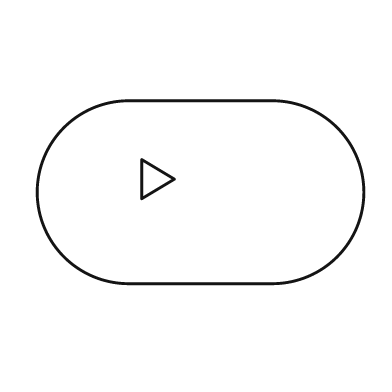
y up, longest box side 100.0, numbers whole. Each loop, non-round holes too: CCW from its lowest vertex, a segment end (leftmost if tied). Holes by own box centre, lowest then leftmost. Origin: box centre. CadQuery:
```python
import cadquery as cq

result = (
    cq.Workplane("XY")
    .moveTo(-22.0, -28.0)
    .lineTo(22.0, -28.0)
    .threePointArc((50.0, 0.0), (22.0, 28.0))
    .lineTo(-22.0, 28.0)
    .threePointArc((-50.0, 0.0), (-22.0, -28.0))
    .close()
    .moveTo(-18.0, -2.0)
    .lineTo(-8.0, 4.0)
    .lineTo(-18.0, 10.0)
    .close()
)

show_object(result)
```